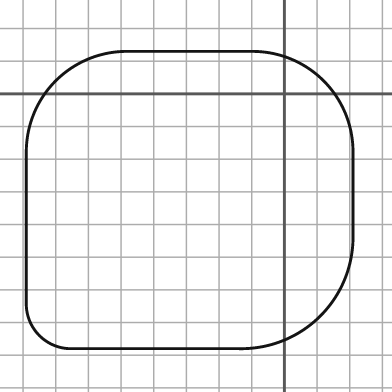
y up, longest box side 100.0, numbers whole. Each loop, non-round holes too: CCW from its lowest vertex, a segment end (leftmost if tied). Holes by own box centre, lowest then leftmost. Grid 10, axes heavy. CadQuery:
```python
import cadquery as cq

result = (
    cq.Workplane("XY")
    .moveTo(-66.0, -78.0)
    .lineTo(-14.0, -78.0)
    .threePointArc((11.0, -68.0), (21.0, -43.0))
    .lineTo(21.0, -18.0)
    .threePointArc((12.0, 4.0), (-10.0, 13.0))
    .lineTo(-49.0, 13.0)
    .threePointArc((-70.0, 4.0), (-79.0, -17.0))
    .lineTo(-79.0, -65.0)
    .threePointArc((-75.0, -74.0), (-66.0, -78.0))
    .close()
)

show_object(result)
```